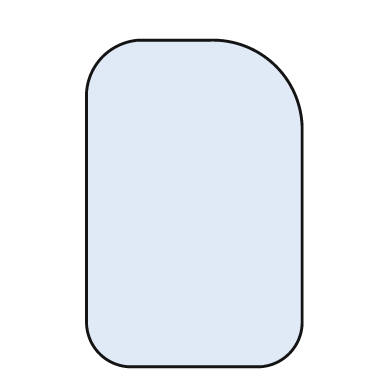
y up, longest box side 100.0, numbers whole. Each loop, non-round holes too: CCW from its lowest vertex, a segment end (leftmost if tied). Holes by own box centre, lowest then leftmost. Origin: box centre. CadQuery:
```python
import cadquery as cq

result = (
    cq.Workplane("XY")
    .moveTo(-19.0, -50.0)
    .lineTo(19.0, -50.0)
    .threePointArc((29.0, -46.0), (33.0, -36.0))
    .lineTo(33.0, 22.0)
    .threePointArc((25.0, 42.0), (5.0, 50.0))
    .lineTo(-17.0, 50.0)
    .threePointArc((-28.0, 45.0), (-33.0, 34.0))
    .lineTo(-33.0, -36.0)
    .threePointArc((-29.0, -46.0), (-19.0, -50.0))
    .close()
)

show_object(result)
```